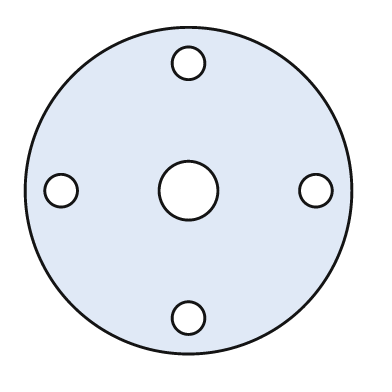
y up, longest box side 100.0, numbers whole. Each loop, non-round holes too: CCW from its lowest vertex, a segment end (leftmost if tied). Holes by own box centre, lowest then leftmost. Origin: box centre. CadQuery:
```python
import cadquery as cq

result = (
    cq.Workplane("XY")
    .moveTo(0.0, 0.0)
    .circle(50.0)
    .moveTo(0.0, -39.0)
    .circle(5.0)
    .moveTo(-39.0, 0.0)
    .circle(5.0)
    .moveTo(0.0, 0.0)
    .circle(9.0)
    .moveTo(39.0, 0.0)
    .circle(5.0)
    .moveTo(0.0, 39.0)
    .circle(5.0)
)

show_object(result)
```